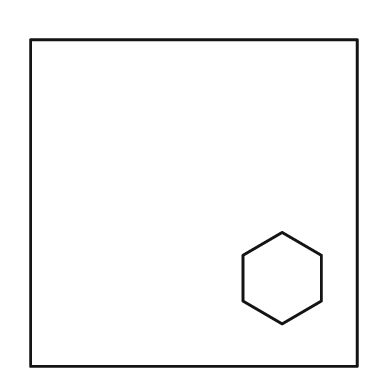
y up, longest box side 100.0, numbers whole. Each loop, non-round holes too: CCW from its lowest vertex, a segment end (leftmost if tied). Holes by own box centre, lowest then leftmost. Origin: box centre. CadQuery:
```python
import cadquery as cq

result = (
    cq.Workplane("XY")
    .moveTo(-50.0, -50.0)
    .lineTo(50.0, -50.0)
    .lineTo(50.0, 50.0)
    .lineTo(-50.0, 50.0)
    .close()
    .moveTo(27.0, -37.0)
    .lineTo(39.0, -30.0)
    .lineTo(39.0, -16.0)
    .lineTo(27.0, -9.0)
    .lineTo(15.0, -16.0)
    .lineTo(15.0, -30.0)
    .close()
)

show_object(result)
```